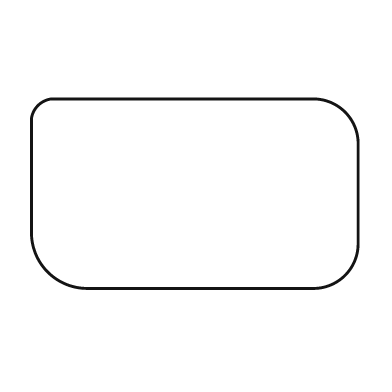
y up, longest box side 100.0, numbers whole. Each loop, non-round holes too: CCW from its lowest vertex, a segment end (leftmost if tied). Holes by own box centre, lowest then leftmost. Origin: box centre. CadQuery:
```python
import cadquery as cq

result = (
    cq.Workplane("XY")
    .moveTo(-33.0, -29.0)
    .lineTo(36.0, -29.0)
    .threePointArc((46.0, -25.0), (50.0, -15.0))
    .lineTo(50.0, 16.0)
    .threePointArc((46.0, 25.0), (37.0, 29.0))
    .lineTo(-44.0, 29.0)
    .threePointArc((-48.0, 27.0), (-50.0, 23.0))
    .lineTo(-50.0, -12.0)
    .threePointArc((-45.0, -24.0), (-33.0, -29.0))
    .close()
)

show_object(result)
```